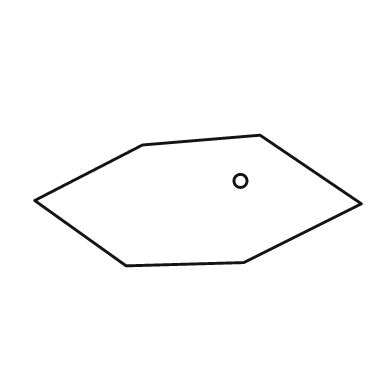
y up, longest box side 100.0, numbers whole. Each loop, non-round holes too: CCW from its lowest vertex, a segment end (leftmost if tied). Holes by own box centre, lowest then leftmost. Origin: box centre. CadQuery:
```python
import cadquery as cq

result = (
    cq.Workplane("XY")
    .moveTo(-22.0, -20.0)
    .lineTo(14.0, -19.0)
    .lineTo(50.0, -1.0)
    .lineTo(19.0, 20.0)
    .lineTo(-17.0, 17.0)
    .lineTo(-50.0, 0.0)
    .close()
    .moveTo(13.0, 6.0)
    .circle(2.0)
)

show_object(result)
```